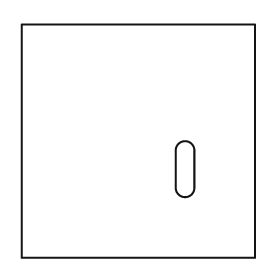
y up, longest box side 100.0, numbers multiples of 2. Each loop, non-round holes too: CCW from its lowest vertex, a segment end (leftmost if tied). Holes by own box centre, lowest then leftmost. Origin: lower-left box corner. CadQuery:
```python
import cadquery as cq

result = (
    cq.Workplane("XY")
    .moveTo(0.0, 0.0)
    .lineTo(100.0, 0.0)
    .lineTo(100.0, 100.0)
    .lineTo(0.0, 100.0)
    .close()
    .moveTo(66.0, 30.0)
    .threePointArc((70.0, 26.0), (74.0, 30.0))
    .lineTo(74.0, 46.0)
    .threePointArc((70.0, 50.0), (66.0, 46.0))
    .close()
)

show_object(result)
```